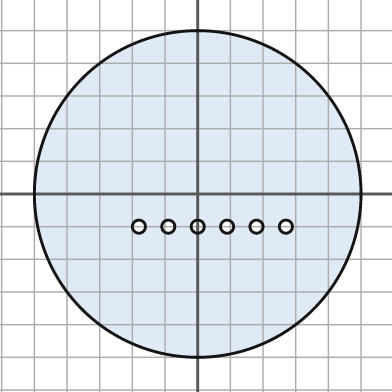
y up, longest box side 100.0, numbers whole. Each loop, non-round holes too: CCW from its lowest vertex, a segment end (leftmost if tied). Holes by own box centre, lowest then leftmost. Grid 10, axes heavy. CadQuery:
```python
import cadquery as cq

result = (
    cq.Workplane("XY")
    .moveTo(0.0, 0.0)
    .circle(50.0)
    .moveTo(-18.0, -10.0)
    .circle(2.0)
    .moveTo(-9.0, -10.0)
    .circle(2.0)
    .moveTo(0.0, -10.0)
    .circle(2.0)
    .moveTo(9.0, -10.0)
    .circle(2.0)
    .moveTo(18.0, -10.0)
    .circle(2.0)
    .moveTo(27.0, -10.0)
    .circle(2.0)
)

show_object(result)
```